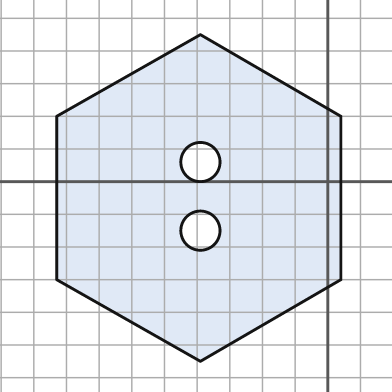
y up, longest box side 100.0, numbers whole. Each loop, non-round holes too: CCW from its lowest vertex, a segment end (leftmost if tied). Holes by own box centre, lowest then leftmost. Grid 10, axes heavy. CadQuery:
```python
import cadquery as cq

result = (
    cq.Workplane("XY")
    .moveTo(-39.0, -55.0)
    .lineTo(4.0, -30.0)
    .lineTo(4.0, 20.0)
    .lineTo(-39.0, 45.0)
    .lineTo(-83.0, 20.0)
    .lineTo(-83.0, -30.0)
    .close()
    .moveTo(-39.0, -15.0)
    .circle(6.0)
    .moveTo(-39.0, 6.0)
    .circle(6.0)
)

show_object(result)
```